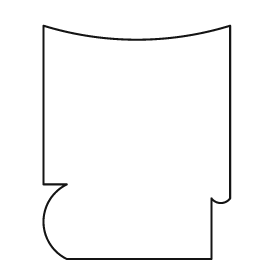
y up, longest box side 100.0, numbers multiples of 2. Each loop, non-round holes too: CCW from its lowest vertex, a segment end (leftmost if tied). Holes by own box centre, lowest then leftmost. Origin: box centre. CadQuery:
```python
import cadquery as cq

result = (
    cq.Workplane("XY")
    .moveTo(-30.0, -50.0)
    .lineTo(32.0, -50.0)
    .lineTo(32.0, -24.0)
    .threePointArc((36.0, -26.0), (40.0, -24.0))
    .lineTo(40.0, 50.0)
    .threePointArc((0.0, 44.0), (-40.0, 50.0))
    .lineTo(-40.0, -18.0)
    .lineTo(-30.0, -18.0)
    .threePointArc((-40.0, -34.0), (-30.0, -50.0))
    .close()
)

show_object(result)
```